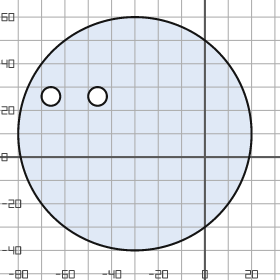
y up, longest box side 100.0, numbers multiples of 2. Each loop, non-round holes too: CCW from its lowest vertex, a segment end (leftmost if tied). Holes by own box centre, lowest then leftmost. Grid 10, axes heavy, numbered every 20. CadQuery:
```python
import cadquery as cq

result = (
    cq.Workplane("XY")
    .moveTo(-30.0, 10.0)
    .circle(50.0)
    .moveTo(-66.0, 26.0)
    .circle(4.0)
    .moveTo(-46.0, 26.0)
    .circle(4.0)
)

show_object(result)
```